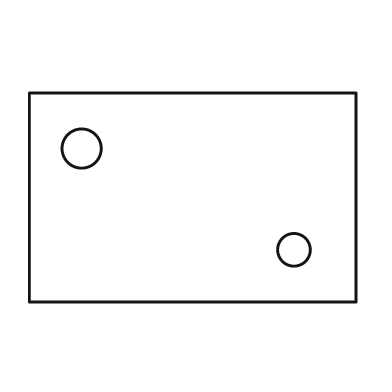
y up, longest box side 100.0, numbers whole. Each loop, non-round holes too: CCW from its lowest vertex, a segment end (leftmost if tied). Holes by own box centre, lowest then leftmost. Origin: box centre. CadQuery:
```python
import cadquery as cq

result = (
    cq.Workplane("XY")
    .moveTo(-50.0, -32.0)
    .lineTo(50.0, -32.0)
    .lineTo(50.0, 32.0)
    .lineTo(-50.0, 32.0)
    .close()
    .moveTo(31.0, -16.0)
    .circle(5.0)
    .moveTo(-34.0, 15.0)
    .circle(6.0)
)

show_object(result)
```